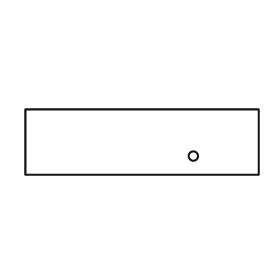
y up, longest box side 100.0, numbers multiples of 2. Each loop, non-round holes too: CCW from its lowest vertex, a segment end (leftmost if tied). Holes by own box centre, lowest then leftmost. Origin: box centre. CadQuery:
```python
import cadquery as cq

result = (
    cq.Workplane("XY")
    .moveTo(-50.0, -14.0)
    .lineTo(50.0, -14.0)
    .lineTo(50.0, 14.0)
    .lineTo(-50.0, 14.0)
    .close()
    .moveTo(22.0, -6.0)
    .circle(2.0)
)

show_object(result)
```